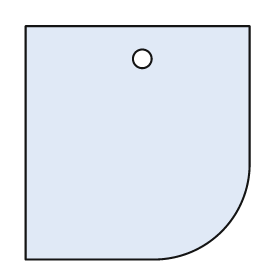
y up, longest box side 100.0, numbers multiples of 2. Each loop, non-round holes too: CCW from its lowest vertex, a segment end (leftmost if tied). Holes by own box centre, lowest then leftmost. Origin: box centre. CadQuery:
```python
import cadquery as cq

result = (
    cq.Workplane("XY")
    .moveTo(-48.0, -50.0)
    .lineTo(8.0, -50.0)
    .threePointArc((36.0, -38.0), (48.0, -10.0))
    .lineTo(48.0, 50.0)
    .lineTo(-48.0, 50.0)
    .close()
    .moveTo(2.0, 36.0)
    .circle(4.0)
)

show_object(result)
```